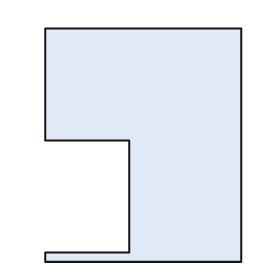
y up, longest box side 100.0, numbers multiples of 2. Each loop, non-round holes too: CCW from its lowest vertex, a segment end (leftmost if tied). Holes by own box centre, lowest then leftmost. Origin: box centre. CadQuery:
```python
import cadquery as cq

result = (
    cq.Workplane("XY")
    .moveTo(-42.0, -50.0)
    .lineTo(42.0, -50.0)
    .lineTo(42.0, 50.0)
    .lineTo(-42.0, 50.0)
    .lineTo(-42.0, 2.0)
    .lineTo(-6.0, 2.0)
    .lineTo(-6.0, -46.0)
    .lineTo(-42.0, -46.0)
    .close()
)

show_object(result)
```